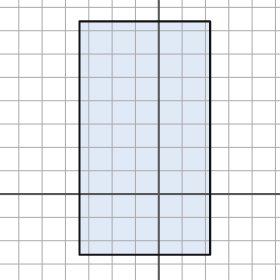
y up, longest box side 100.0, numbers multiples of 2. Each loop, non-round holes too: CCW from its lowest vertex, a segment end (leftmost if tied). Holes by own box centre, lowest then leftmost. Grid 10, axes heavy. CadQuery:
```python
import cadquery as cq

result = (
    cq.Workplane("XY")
    .moveTo(-34.0, -26.0)
    .lineTo(22.0, -26.0)
    .lineTo(22.0, 74.0)
    .lineTo(-34.0, 74.0)
    .close()
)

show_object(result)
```